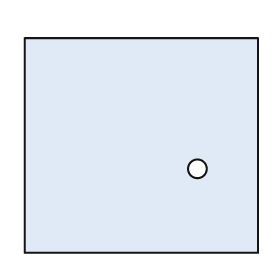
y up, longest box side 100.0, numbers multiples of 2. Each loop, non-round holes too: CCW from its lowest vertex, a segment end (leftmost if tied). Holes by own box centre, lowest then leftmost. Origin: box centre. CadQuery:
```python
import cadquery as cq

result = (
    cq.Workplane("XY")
    .moveTo(-50.0, -46.0)
    .lineTo(50.0, -46.0)
    .lineTo(50.0, 46.0)
    .lineTo(-50.0, 46.0)
    .close()
    .moveTo(24.0, -10.0)
    .circle(4.0)
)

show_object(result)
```